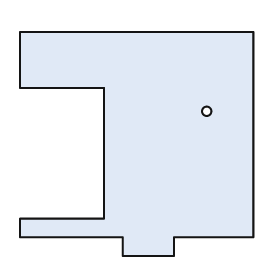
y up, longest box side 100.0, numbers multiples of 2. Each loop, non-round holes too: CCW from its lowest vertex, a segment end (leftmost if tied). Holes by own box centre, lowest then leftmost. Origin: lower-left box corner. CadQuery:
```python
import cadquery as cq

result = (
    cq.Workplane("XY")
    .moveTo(44.0, 0.0)
    .lineTo(66.0, 0.0)
    .lineTo(66.0, 8.0)
    .lineTo(100.0, 8.0)
    .lineTo(100.0, 96.0)
    .lineTo(0.0, 96.0)
    .lineTo(0.0, 72.0)
    .lineTo(36.0, 72.0)
    .lineTo(36.0, 16.0)
    .lineTo(0.0, 16.0)
    .lineTo(0.0, 8.0)
    .lineTo(44.0, 8.0)
    .close()
    .moveTo(80.0, 62.0)
    .circle(2.0)
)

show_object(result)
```